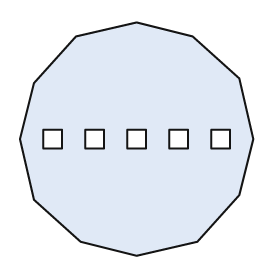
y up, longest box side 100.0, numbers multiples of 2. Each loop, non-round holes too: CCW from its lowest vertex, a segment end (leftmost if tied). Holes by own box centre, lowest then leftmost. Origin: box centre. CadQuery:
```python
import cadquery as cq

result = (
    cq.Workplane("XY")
    .moveTo(0.0, -50.0)
    .lineTo(26.0, -44.0)
    .lineTo(44.0, -24.0)
    .lineTo(50.0, 0.0)
    .lineTo(44.0, 26.0)
    .lineTo(24.0, 44.0)
    .lineTo(0.0, 50.0)
    .lineTo(-26.0, 44.0)
    .lineTo(-44.0, 24.0)
    .lineTo(-50.0, 0.0)
    .lineTo(-44.0, -26.0)
    .lineTo(-24.0, -44.0)
    .close()
    .moveTo(-40.0, -4.0)
    .lineTo(-32.0, -4.0)
    .lineTo(-32.0, 4.0)
    .lineTo(-40.0, 4.0)
    .close()
    .moveTo(-22.0, -4.0)
    .lineTo(-14.0, -4.0)
    .lineTo(-14.0, 4.0)
    .lineTo(-22.0, 4.0)
    .close()
    .moveTo(-4.0, -4.0)
    .lineTo(4.0, -4.0)
    .lineTo(4.0, 4.0)
    .lineTo(-4.0, 4.0)
    .close()
    .moveTo(14.0, -4.0)
    .lineTo(22.0, -4.0)
    .lineTo(22.0, 4.0)
    .lineTo(14.0, 4.0)
    .close()
    .moveTo(32.0, -4.0)
    .lineTo(40.0, -4.0)
    .lineTo(40.0, 4.0)
    .lineTo(32.0, 4.0)
    .close()
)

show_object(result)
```